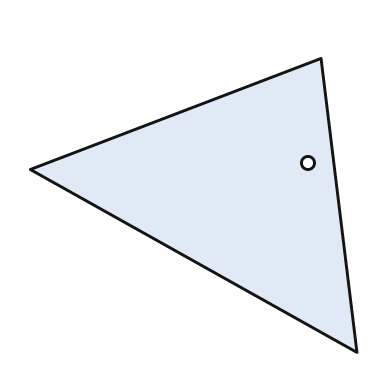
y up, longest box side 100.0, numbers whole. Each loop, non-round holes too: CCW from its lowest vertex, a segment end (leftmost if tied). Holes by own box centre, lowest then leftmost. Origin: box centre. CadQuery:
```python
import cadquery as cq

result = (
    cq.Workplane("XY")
    .moveTo(50.0, -45.0)
    .lineTo(39.0, 45.0)
    .lineTo(-50.0, 11.0)
    .close()
    .moveTo(35.0, 13.0)
    .circle(2.0)
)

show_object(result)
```